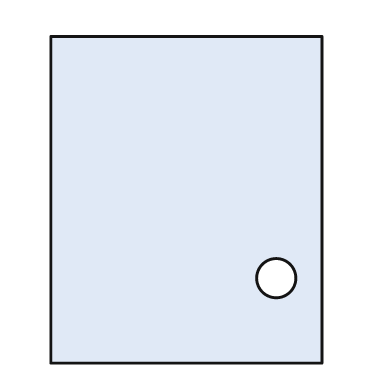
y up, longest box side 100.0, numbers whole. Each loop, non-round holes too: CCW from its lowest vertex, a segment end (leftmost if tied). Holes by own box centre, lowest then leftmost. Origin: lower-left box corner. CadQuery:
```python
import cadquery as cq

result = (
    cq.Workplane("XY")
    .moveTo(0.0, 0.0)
    .lineTo(83.0, 0.0)
    .lineTo(83.0, 100.0)
    .lineTo(0.0, 100.0)
    .close()
    .moveTo(69.0, 26.0)
    .circle(6.0)
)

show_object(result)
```